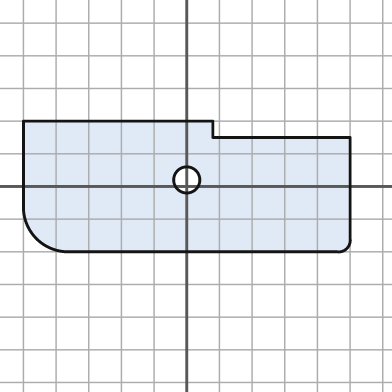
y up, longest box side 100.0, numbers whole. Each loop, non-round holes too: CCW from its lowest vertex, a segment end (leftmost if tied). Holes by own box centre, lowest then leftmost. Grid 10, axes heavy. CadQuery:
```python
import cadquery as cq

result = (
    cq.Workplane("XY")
    .moveTo(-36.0, -20.0)
    .lineTo(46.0, -20.0)
    .threePointArc((49.0, -19.0), (50.0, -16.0))
    .lineTo(50.0, 15.0)
    .lineTo(8.0, 15.0)
    .lineTo(8.0, 20.0)
    .lineTo(-50.0, 20.0)
    .lineTo(-50.0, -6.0)
    .threePointArc((-46.0, -16.0), (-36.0, -20.0))
    .close()
    .moveTo(0.0, 2.0)
    .circle(4.0)
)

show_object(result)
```